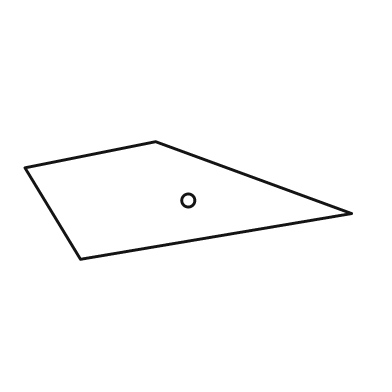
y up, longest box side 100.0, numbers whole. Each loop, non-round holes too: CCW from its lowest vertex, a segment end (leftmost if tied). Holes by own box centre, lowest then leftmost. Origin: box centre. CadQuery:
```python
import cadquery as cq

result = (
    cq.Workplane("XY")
    .moveTo(-33.0, -18.0)
    .lineTo(50.0, -4.0)
    .lineTo(-10.0, 18.0)
    .lineTo(-50.0, 10.0)
    .close()
    .moveTo(0.0, 0.0)
    .circle(2.0)
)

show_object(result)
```